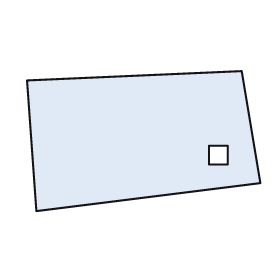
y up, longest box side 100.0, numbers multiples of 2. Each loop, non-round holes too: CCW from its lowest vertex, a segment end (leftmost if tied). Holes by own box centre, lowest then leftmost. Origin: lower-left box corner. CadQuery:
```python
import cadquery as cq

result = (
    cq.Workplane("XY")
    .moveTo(4.0, 0.0)
    .lineTo(100.0, 12.0)
    .lineTo(92.0, 60.0)
    .lineTo(0.0, 56.0)
    .close()
    .moveTo(78.0, 20.0)
    .lineTo(86.0, 20.0)
    .lineTo(86.0, 28.0)
    .lineTo(78.0, 28.0)
    .close()
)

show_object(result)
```